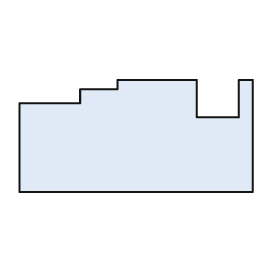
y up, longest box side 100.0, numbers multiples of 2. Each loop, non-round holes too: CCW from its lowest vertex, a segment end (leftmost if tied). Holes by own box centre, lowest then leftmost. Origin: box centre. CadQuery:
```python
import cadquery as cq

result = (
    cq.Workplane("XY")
    .moveTo(-50.0, -24.0)
    .lineTo(50.0, -24.0)
    .lineTo(50.0, 24.0)
    .lineTo(44.0, 24.0)
    .lineTo(44.0, 8.0)
    .lineTo(26.0, 8.0)
    .lineTo(26.0, 24.0)
    .lineTo(-8.0, 24.0)
    .lineTo(-8.0, 20.0)
    .lineTo(-24.0, 20.0)
    .lineTo(-24.0, 14.0)
    .lineTo(-50.0, 14.0)
    .close()
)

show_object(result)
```